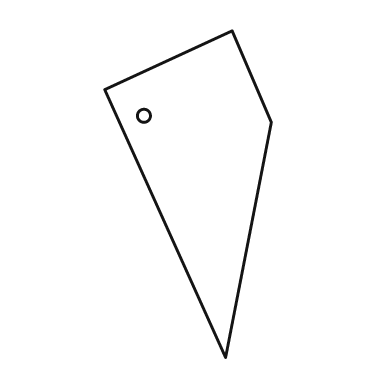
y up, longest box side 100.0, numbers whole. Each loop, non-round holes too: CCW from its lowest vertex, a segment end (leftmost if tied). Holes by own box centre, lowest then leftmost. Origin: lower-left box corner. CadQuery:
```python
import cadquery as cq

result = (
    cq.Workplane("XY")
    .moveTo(37.0, 0.0)
    .lineTo(51.0, 72.0)
    .lineTo(39.0, 100.0)
    .lineTo(0.0, 82.0)
    .close()
    .moveTo(12.0, 74.0)
    .circle(2.0)
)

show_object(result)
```